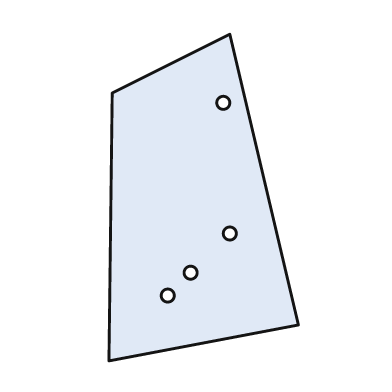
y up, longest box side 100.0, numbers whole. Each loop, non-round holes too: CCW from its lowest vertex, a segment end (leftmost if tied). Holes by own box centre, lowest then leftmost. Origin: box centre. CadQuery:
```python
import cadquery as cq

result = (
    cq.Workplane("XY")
    .moveTo(-29.0, -50.0)
    .lineTo(29.0, -39.0)
    .lineTo(8.0, 50.0)
    .lineTo(-28.0, 32.0)
    .close()
    .moveTo(-11.0, -30.0)
    .circle(2.0)
    .moveTo(-4.0, -23.0)
    .circle(2.0)
    .moveTo(8.0, -11.0)
    .circle(2.0)
    .moveTo(6.0, 29.0)
    .circle(2.0)
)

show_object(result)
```